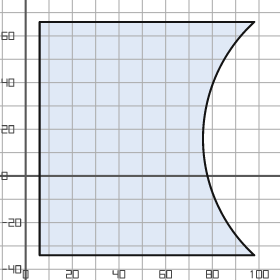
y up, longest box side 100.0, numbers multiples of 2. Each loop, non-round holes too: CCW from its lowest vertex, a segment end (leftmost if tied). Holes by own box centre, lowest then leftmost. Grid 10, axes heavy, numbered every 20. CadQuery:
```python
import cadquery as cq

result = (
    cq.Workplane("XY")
    .moveTo(6.0, -34.0)
    .lineTo(98.0, -34.0)
    .threePointArc((76.0, 16.0), (98.0, 66.0))
    .lineTo(6.0, 66.0)
    .close()
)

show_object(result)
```